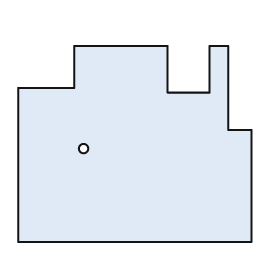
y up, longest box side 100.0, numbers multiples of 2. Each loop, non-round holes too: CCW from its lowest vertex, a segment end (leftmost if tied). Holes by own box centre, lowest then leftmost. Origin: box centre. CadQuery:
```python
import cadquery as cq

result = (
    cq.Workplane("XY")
    .moveTo(-50.0, -42.0)
    .lineTo(50.0, -42.0)
    .lineTo(50.0, 6.0)
    .lineTo(40.0, 6.0)
    .lineTo(40.0, 42.0)
    .lineTo(32.0, 42.0)
    .lineTo(32.0, 22.0)
    .lineTo(14.0, 22.0)
    .lineTo(14.0, 42.0)
    .lineTo(-26.0, 42.0)
    .lineTo(-26.0, 24.0)
    .lineTo(-50.0, 24.0)
    .close()
    .moveTo(-22.0, -2.0)
    .circle(2.0)
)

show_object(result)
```